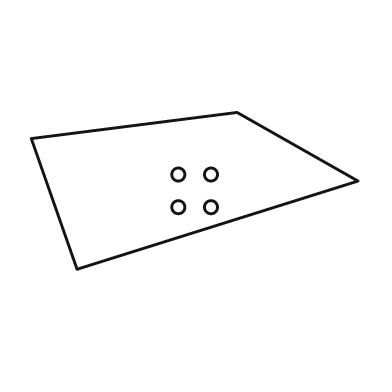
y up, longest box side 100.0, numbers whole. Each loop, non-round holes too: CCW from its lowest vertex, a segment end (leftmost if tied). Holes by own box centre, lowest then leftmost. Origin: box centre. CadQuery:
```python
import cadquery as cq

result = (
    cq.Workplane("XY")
    .moveTo(-36.0, -24.0)
    .lineTo(50.0, 3.0)
    .lineTo(13.0, 24.0)
    .lineTo(-50.0, 16.0)
    .close()
    .moveTo(-5.0, -5.0)
    .circle(2.0)
    .moveTo(5.0, -5.0)
    .circle(2.0)
    .moveTo(-5.0, 5.0)
    .circle(2.0)
    .moveTo(5.0, 5.0)
    .circle(2.0)
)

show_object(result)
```